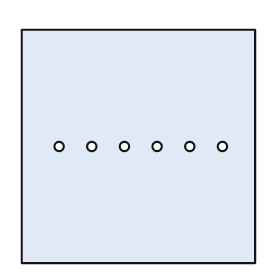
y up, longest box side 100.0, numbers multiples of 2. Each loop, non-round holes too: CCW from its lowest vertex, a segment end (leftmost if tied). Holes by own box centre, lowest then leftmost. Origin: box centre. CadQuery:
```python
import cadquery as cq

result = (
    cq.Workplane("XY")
    .moveTo(-50.0, -50.0)
    .lineTo(50.0, -50.0)
    .lineTo(50.0, 50.0)
    .lineTo(-50.0, 50.0)
    .close()
    .moveTo(-34.0, 0.0)
    .circle(2.0)
    .moveTo(-20.0, 0.0)
    .circle(2.0)
    .moveTo(-6.0, 0.0)
    .circle(2.0)
    .moveTo(8.0, 0.0)
    .circle(2.0)
    .moveTo(22.0, 0.0)
    .circle(2.0)
    .moveTo(36.0, 0.0)
    .circle(2.0)
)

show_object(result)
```